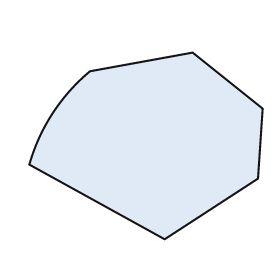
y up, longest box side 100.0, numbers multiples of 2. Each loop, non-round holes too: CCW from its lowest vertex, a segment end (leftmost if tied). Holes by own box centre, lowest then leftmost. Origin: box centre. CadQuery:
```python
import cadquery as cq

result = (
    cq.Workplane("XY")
    .moveTo(8.0, -40.0)
    .lineTo(48.0, -14.0)
    .lineTo(50.0, 16.0)
    .lineTo(20.0, 40.0)
    .lineTo(-24.0, 32.0)
    .threePointArc((-40.0, 14.0), (-50.0, -8.0))
    .close()
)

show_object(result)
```